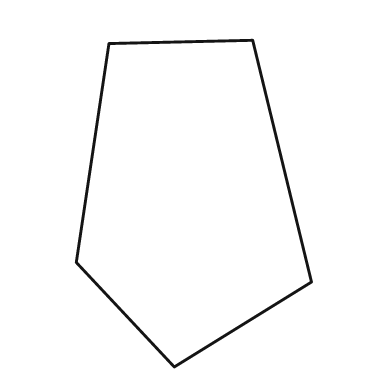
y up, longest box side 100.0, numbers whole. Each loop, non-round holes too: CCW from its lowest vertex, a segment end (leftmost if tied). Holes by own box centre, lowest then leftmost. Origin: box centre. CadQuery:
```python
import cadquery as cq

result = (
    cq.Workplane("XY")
    .moveTo(-6.0, -50.0)
    .lineTo(36.0, -24.0)
    .lineTo(18.0, 50.0)
    .lineTo(-26.0, 49.0)
    .lineTo(-36.0, -18.0)
    .close()
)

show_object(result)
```